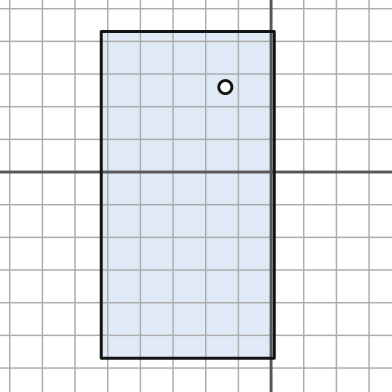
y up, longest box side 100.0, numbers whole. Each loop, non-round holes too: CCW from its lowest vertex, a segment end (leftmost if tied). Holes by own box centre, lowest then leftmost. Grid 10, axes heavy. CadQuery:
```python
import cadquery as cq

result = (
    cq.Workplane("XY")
    .moveTo(-52.0, -57.0)
    .lineTo(1.0, -57.0)
    .lineTo(1.0, 43.0)
    .lineTo(-52.0, 43.0)
    .close()
    .moveTo(-14.0, 26.0)
    .circle(2.0)
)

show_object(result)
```